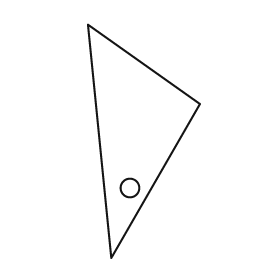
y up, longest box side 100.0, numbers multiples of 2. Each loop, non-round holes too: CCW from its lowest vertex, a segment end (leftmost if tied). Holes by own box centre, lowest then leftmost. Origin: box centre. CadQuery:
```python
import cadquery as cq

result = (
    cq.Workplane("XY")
    .moveTo(-14.0, -50.0)
    .lineTo(24.0, 16.0)
    .lineTo(-24.0, 50.0)
    .close()
    .moveTo(-6.0, -20.0)
    .circle(4.0)
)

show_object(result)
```